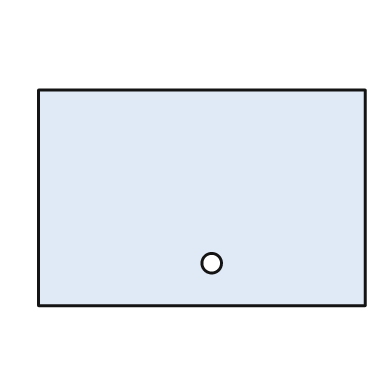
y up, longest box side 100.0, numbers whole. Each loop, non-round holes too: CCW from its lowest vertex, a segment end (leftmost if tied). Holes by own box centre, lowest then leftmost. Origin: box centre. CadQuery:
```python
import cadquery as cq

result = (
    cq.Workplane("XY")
    .moveTo(-50.0, -33.0)
    .lineTo(50.0, -33.0)
    .lineTo(50.0, 33.0)
    .lineTo(-50.0, 33.0)
    .close()
    .moveTo(3.0, -20.0)
    .circle(3.0)
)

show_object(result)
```